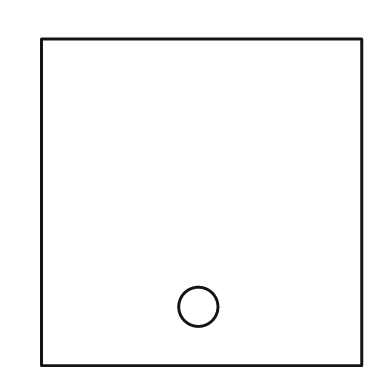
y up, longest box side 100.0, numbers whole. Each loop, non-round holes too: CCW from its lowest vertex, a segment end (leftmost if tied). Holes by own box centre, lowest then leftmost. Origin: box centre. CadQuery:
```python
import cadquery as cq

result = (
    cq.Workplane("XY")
    .moveTo(-49.0, -50.0)
    .lineTo(49.0, -50.0)
    .lineTo(49.0, 50.0)
    .lineTo(-49.0, 50.0)
    .close()
    .moveTo(-1.0, -32.0)
    .circle(6.0)
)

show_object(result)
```